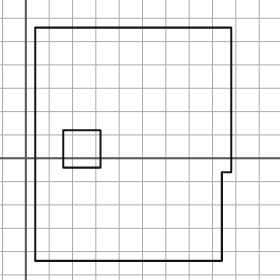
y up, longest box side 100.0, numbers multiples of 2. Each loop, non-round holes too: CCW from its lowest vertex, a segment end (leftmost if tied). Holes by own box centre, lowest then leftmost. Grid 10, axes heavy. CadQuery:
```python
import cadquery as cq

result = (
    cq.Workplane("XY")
    .moveTo(4.0, -44.0)
    .lineTo(84.0, -44.0)
    .lineTo(84.0, -6.0)
    .lineTo(88.0, -6.0)
    .lineTo(88.0, 56.0)
    .lineTo(4.0, 56.0)
    .close()
    .moveTo(16.0, -4.0)
    .lineTo(32.0, -4.0)
    .lineTo(32.0, 12.0)
    .lineTo(16.0, 12.0)
    .close()
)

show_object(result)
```